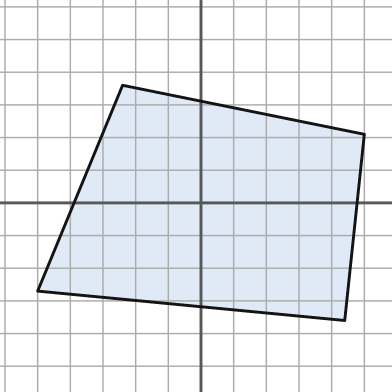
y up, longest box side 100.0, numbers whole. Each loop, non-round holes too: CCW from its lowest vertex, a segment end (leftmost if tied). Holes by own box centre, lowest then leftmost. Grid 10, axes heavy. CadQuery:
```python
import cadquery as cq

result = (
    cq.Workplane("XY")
    .moveTo(44.0, -36.0)
    .lineTo(50.0, 21.0)
    .lineTo(-24.0, 36.0)
    .lineTo(-50.0, -27.0)
    .close()
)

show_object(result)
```